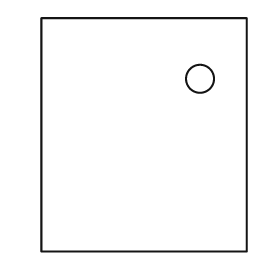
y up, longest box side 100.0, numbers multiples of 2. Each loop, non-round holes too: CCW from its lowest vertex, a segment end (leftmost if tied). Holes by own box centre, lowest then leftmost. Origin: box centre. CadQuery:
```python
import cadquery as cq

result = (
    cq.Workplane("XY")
    .moveTo(-44.0, -50.0)
    .lineTo(44.0, -50.0)
    .lineTo(44.0, 50.0)
    .lineTo(-44.0, 50.0)
    .close()
    .moveTo(24.0, 24.0)
    .circle(6.0)
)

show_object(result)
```